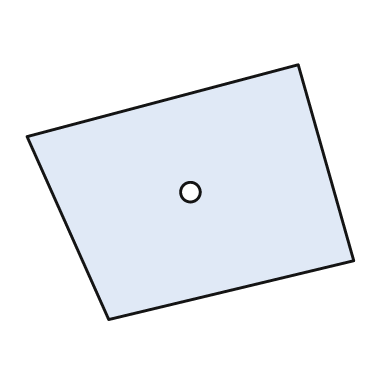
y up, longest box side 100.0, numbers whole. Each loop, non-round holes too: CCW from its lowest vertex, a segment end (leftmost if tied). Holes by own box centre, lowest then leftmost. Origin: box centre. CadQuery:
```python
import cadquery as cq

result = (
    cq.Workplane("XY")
    .moveTo(-25.0, -39.0)
    .lineTo(50.0, -21.0)
    .lineTo(33.0, 39.0)
    .lineTo(-50.0, 17.0)
    .close()
    .moveTo(0.0, 0.0)
    .circle(3.0)
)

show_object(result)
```